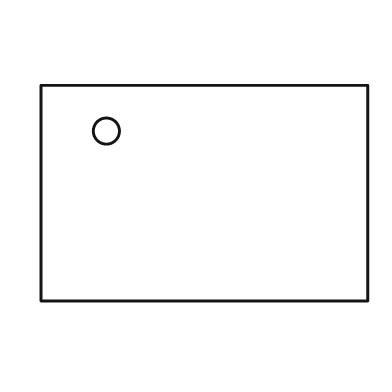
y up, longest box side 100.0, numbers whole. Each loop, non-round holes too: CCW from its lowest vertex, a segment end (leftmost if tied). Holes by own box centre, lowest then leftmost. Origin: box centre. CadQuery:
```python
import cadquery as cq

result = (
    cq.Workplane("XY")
    .moveTo(-50.0, -33.0)
    .lineTo(50.0, -33.0)
    .lineTo(50.0, 33.0)
    .lineTo(-50.0, 33.0)
    .close()
    .moveTo(-30.0, 19.0)
    .circle(4.0)
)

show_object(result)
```